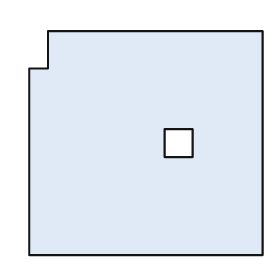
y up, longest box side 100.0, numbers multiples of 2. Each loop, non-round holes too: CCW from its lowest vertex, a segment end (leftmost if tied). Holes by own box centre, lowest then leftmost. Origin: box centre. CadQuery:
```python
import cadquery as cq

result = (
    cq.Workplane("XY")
    .moveTo(-50.0, -48.0)
    .lineTo(50.0, -48.0)
    .lineTo(50.0, 48.0)
    .lineTo(-42.0, 48.0)
    .lineTo(-42.0, 32.0)
    .lineTo(-50.0, 32.0)
    .close()
    .moveTo(8.0, -6.0)
    .lineTo(20.0, -6.0)
    .lineTo(20.0, 6.0)
    .lineTo(8.0, 6.0)
    .close()
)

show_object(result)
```